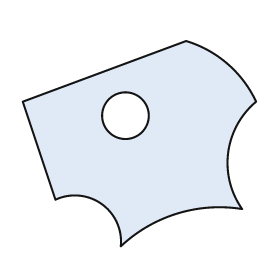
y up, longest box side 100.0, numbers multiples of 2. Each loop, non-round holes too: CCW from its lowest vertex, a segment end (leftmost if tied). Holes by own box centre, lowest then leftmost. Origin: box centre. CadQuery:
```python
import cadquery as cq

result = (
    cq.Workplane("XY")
    .moveTo(-8.0, -44.0)
    .threePointArc((16.0, -30.0), (44.0, -28.0))
    .threePointArc((38.0, -4.0), (50.0, 18.0))
    .threePointArc((38.0, 34.0), (20.0, 44.0))
    .lineTo(-50.0, 18.0)
    .lineTo(-36.0, -24.0)
    .threePointArc((-16.0, -26.0), (-8.0, -44.0))
    .close()
    .moveTo(-6.0, 12.0)
    .circle(10.0)
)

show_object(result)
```